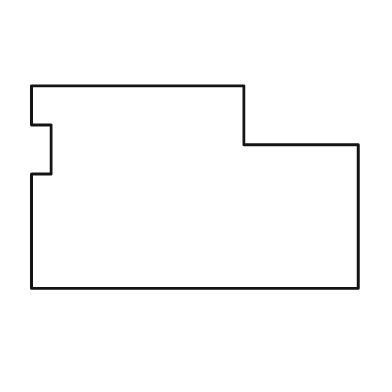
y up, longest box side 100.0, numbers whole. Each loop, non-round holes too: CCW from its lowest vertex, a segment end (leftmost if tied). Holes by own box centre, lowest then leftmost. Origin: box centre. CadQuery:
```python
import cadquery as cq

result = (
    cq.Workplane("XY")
    .moveTo(-50.0, -31.0)
    .lineTo(50.0, -31.0)
    .lineTo(50.0, 13.0)
    .lineTo(15.0, 13.0)
    .lineTo(15.0, 31.0)
    .lineTo(-50.0, 31.0)
    .lineTo(-50.0, 19.0)
    .lineTo(-44.0, 19.0)
    .lineTo(-44.0, 4.0)
    .lineTo(-50.0, 4.0)
    .close()
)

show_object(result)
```